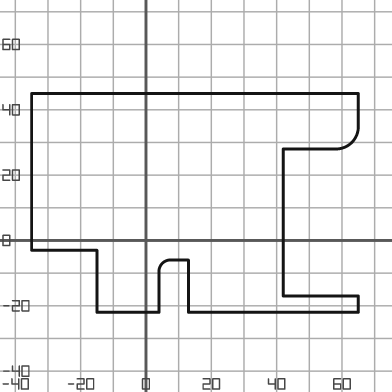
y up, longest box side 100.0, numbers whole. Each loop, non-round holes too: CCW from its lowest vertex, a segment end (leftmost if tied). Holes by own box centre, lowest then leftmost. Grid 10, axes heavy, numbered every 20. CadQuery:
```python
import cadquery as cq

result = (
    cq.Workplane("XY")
    .moveTo(-15.0, -22.0)
    .lineTo(4.0, -22.0)
    .lineTo(4.0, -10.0)
    .threePointArc((5.0, -7.0), (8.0, -6.0))
    .lineTo(13.0, -6.0)
    .lineTo(13.0, -22.0)
    .lineTo(65.0, -22.0)
    .lineTo(65.0, -17.0)
    .lineTo(42.0, -17.0)
    .lineTo(42.0, 28.0)
    .lineTo(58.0, 28.0)
    .threePointArc((63.0, 30.0), (65.0, 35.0))
    .lineTo(65.0, 45.0)
    .lineTo(-35.0, 45.0)
    .lineTo(-35.0, -3.0)
    .lineTo(-15.0, -3.0)
    .close()
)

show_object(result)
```